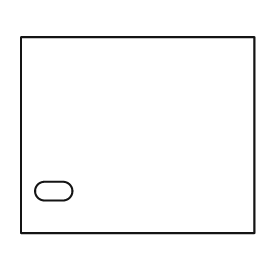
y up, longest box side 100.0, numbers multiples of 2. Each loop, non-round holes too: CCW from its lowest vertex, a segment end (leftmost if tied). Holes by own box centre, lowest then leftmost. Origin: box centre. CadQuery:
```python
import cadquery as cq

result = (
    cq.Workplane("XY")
    .moveTo(-50.0, -42.0)
    .lineTo(50.0, -42.0)
    .lineTo(50.0, 42.0)
    .lineTo(-50.0, 42.0)
    .close()
    .moveTo(-40.0, -28.0)
    .lineTo(-32.0, -28.0)
    .threePointArc((-28.0, -24.0), (-32.0, -20.0))
    .lineTo(-40.0, -20.0)
    .threePointArc((-44.0, -24.0), (-40.0, -28.0))
    .close()
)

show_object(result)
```